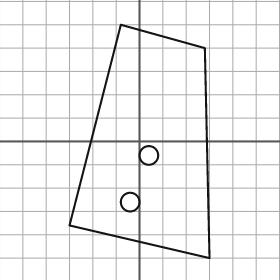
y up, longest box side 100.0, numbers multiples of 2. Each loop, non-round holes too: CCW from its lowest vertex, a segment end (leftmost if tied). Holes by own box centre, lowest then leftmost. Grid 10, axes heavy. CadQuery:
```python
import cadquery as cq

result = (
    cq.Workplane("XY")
    .moveTo(30.0, -50.0)
    .lineTo(28.0, 40.0)
    .lineTo(-8.0, 50.0)
    .lineTo(-30.0, -36.0)
    .close()
    .moveTo(-4.0, -26.0)
    .circle(4.0)
    .moveTo(4.0, -6.0)
    .circle(4.0)
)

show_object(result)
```